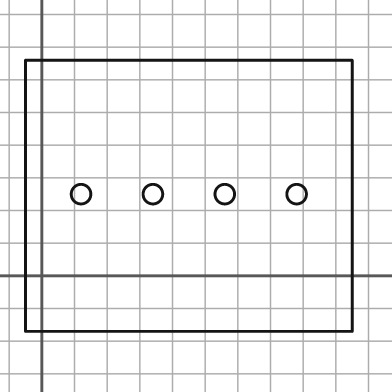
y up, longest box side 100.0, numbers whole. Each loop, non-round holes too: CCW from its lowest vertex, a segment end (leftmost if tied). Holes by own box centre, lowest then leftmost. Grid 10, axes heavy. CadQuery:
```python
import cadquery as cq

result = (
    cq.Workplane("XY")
    .moveTo(-5.0, -17.0)
    .lineTo(95.0, -17.0)
    .lineTo(95.0, 66.0)
    .lineTo(-5.0, 66.0)
    .close()
    .moveTo(12.0, 25.0)
    .circle(3.0)
    .moveTo(34.0, 25.0)
    .circle(3.0)
    .moveTo(56.0, 25.0)
    .circle(3.0)
    .moveTo(78.0, 25.0)
    .circle(3.0)
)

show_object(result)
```